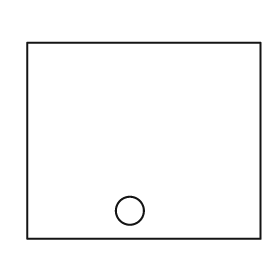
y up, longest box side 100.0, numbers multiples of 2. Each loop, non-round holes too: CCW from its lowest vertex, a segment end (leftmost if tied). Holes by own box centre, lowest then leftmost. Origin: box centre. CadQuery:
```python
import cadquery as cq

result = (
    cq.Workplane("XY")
    .moveTo(-50.0, -42.0)
    .lineTo(50.0, -42.0)
    .lineTo(50.0, 42.0)
    .lineTo(-50.0, 42.0)
    .close()
    .moveTo(-6.0, -30.0)
    .circle(6.0)
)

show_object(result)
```